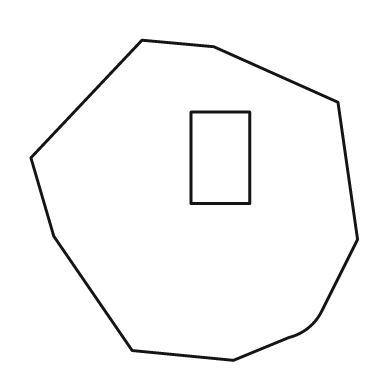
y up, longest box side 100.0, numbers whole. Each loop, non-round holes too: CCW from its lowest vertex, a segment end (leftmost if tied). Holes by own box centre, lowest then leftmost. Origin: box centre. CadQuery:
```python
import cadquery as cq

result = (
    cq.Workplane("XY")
    .moveTo(12.0, -49.0)
    .lineTo(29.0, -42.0)
    .threePointArc((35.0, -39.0), (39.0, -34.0))
    .lineTo(50.0, -12.0)
    .lineTo(44.0, 30.0)
    .lineTo(6.0, 47.0)
    .lineTo(-16.0, 49.0)
    .lineTo(-50.0, 13.0)
    .lineTo(-43.0, -11.0)
    .lineTo(-19.0, -46.0)
    .close()
    .moveTo(-1.0, -1.0)
    .lineTo(17.0, -1.0)
    .lineTo(17.0, 27.0)
    .lineTo(-1.0, 27.0)
    .close()
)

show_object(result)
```